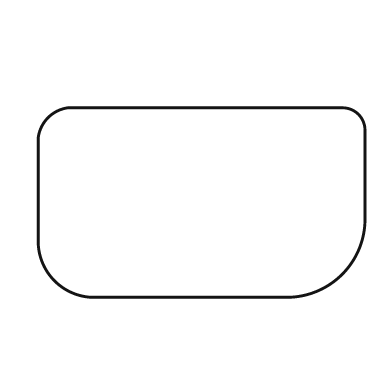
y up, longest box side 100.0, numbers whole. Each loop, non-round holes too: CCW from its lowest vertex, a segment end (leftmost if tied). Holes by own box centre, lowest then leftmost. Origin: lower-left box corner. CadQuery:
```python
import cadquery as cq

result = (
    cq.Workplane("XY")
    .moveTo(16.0, 0.0)
    .lineTo(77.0, 0.0)
    .threePointArc((93.0, 7.0), (100.0, 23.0))
    .lineTo(100.0, 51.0)
    .threePointArc((98.0, 56.0), (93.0, 58.0))
    .lineTo(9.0, 58.0)
    .threePointArc((3.0, 55.0), (0.0, 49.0))
    .lineTo(0.0, 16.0)
    .threePointArc((5.0, 5.0), (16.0, 0.0))
    .close()
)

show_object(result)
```